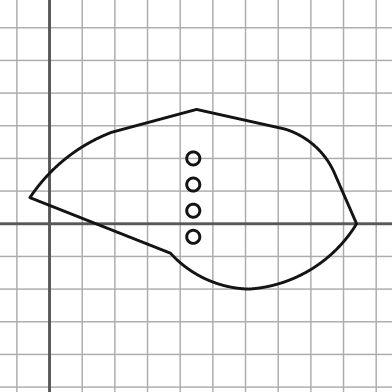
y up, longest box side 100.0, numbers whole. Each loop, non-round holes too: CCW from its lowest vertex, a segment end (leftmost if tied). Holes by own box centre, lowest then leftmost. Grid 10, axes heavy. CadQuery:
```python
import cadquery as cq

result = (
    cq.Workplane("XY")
    .moveTo(61.0, -20.0)
    .threePointArc((80.0, -14.0), (94.0, 0.0))
    .lineTo(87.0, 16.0)
    .threePointArc((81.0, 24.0), (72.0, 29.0))
    .lineTo(45.0, 35.0)
    .lineTo(19.0, 28.0)
    .threePointArc((5.0, 20.0), (-6.0, 8.0))
    .lineTo(37.0, -9.0)
    .threePointArc((48.0, -17.0), (61.0, -20.0))
    .close()
    .moveTo(44.0, -4.0)
    .circle(2.0)
    .moveTo(44.0, 4.0)
    .circle(2.0)
    .moveTo(44.0, 12.0)
    .circle(2.0)
    .moveTo(44.0, 20.0)
    .circle(2.0)
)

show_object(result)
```